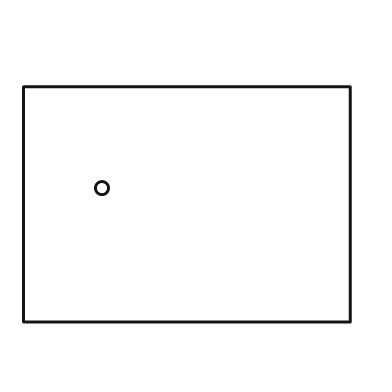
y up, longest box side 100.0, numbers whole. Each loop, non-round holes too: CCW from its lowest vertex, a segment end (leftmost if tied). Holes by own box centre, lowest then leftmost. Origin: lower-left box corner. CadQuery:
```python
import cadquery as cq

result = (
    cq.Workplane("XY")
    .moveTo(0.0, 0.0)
    .lineTo(100.0, 0.0)
    .lineTo(100.0, 72.0)
    .lineTo(0.0, 72.0)
    .close()
    .moveTo(24.0, 41.0)
    .circle(2.0)
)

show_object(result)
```